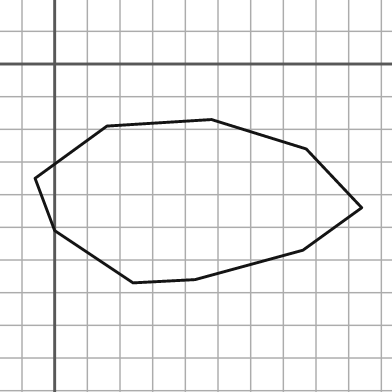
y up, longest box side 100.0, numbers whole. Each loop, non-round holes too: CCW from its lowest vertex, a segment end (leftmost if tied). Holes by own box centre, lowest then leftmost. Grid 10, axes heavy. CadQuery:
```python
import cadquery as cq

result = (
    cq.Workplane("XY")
    .moveTo(24.0, -67.0)
    .lineTo(43.0, -66.0)
    .lineTo(76.0, -57.0)
    .lineTo(94.0, -44.0)
    .lineTo(77.0, -26.0)
    .lineTo(48.0, -17.0)
    .lineTo(16.0, -19.0)
    .lineTo(-6.0, -35.0)
    .lineTo(0.0, -51.0)
    .close()
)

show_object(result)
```